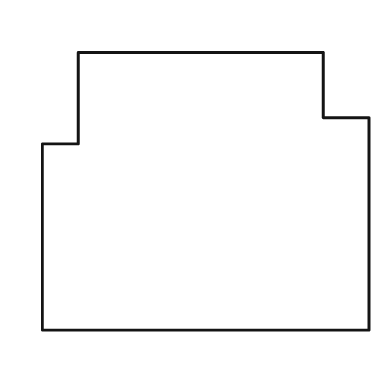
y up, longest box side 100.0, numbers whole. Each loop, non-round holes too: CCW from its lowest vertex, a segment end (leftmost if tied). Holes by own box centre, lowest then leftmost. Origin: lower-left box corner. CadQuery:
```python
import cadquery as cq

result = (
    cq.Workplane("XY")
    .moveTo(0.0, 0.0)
    .lineTo(100.0, 0.0)
    .lineTo(100.0, 65.0)
    .lineTo(86.0, 65.0)
    .lineTo(86.0, 85.0)
    .lineTo(11.0, 85.0)
    .lineTo(11.0, 57.0)
    .lineTo(0.0, 57.0)
    .close()
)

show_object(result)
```